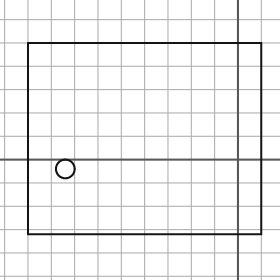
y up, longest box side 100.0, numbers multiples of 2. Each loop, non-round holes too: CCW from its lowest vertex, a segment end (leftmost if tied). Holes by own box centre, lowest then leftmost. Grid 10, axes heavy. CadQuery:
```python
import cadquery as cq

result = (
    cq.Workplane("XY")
    .moveTo(-90.0, -32.0)
    .lineTo(10.0, -32.0)
    .lineTo(10.0, 50.0)
    .lineTo(-90.0, 50.0)
    .close()
    .moveTo(-74.0, -4.0)
    .circle(4.0)
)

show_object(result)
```